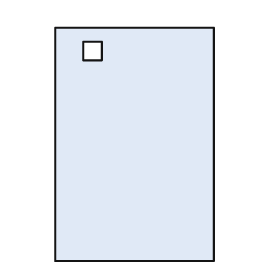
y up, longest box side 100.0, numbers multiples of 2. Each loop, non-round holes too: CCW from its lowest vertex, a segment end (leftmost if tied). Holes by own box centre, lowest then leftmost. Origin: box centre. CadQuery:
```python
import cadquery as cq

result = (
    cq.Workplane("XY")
    .moveTo(-34.0, -50.0)
    .lineTo(34.0, -50.0)
    .lineTo(34.0, 50.0)
    .lineTo(-34.0, 50.0)
    .close()
    .moveTo(-22.0, 36.0)
    .lineTo(-14.0, 36.0)
    .lineTo(-14.0, 44.0)
    .lineTo(-22.0, 44.0)
    .close()
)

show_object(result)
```